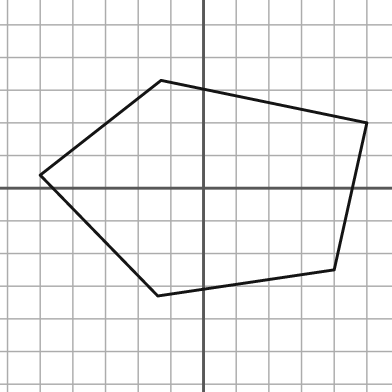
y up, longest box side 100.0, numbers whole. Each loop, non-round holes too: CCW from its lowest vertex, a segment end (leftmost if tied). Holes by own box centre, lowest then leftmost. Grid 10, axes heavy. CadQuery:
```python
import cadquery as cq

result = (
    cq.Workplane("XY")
    .moveTo(-14.0, -33.0)
    .lineTo(40.0, -25.0)
    .lineTo(50.0, 20.0)
    .lineTo(-13.0, 33.0)
    .lineTo(-50.0, 4.0)
    .close()
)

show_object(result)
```